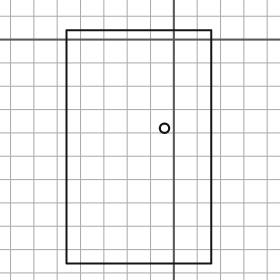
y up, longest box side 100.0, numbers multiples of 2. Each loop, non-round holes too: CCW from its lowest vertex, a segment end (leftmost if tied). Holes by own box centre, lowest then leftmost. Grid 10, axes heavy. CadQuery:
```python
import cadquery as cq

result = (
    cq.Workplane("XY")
    .moveTo(-46.0, -96.0)
    .lineTo(16.0, -96.0)
    .lineTo(16.0, 4.0)
    .lineTo(-46.0, 4.0)
    .close()
    .moveTo(-4.0, -38.0)
    .circle(2.0)
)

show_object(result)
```